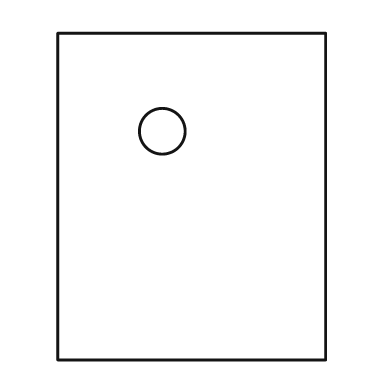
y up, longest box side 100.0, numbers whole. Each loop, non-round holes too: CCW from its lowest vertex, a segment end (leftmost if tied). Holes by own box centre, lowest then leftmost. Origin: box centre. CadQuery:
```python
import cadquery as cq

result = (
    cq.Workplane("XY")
    .moveTo(-41.0, -50.0)
    .lineTo(41.0, -50.0)
    .lineTo(41.0, 50.0)
    .lineTo(-41.0, 50.0)
    .close()
    .moveTo(-9.0, 20.0)
    .circle(7.0)
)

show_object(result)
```